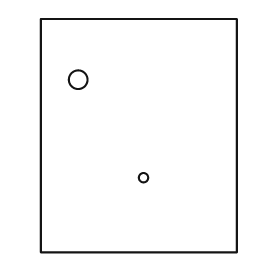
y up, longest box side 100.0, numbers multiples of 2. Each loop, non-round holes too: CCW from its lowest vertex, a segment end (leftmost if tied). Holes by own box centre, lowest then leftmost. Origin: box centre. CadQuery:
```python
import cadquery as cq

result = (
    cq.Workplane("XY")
    .moveTo(-42.0, -50.0)
    .lineTo(42.0, -50.0)
    .lineTo(42.0, 50.0)
    .lineTo(-42.0, 50.0)
    .close()
    .moveTo(2.0, -18.0)
    .circle(2.0)
    .moveTo(-26.0, 24.0)
    .circle(4.0)
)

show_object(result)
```